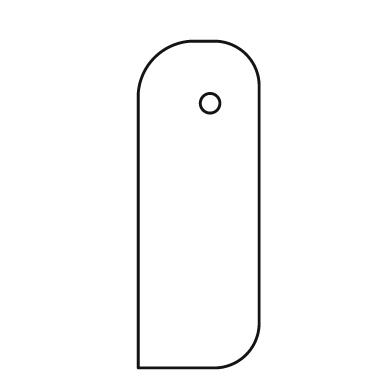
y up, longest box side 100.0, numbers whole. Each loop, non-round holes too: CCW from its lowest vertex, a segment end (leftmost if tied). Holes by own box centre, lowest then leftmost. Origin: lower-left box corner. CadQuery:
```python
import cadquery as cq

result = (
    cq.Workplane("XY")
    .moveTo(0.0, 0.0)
    .lineTo(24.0, 0.0)
    .threePointArc((33.0, 4.0), (37.0, 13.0))
    .lineTo(37.0, 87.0)
    .threePointArc((33.0, 96.0), (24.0, 100.0))
    .lineTo(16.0, 100.0)
    .threePointArc((5.0, 95.0), (0.0, 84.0))
    .close()
    .moveTo(22.0, 81.0)
    .circle(3.0)
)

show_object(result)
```